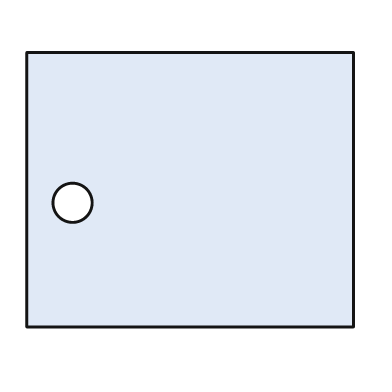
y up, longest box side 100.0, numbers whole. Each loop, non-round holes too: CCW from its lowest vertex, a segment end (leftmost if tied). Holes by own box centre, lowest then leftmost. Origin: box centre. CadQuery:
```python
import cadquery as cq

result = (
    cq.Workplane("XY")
    .moveTo(-50.0, -42.0)
    .lineTo(50.0, -42.0)
    .lineTo(50.0, 42.0)
    .lineTo(-50.0, 42.0)
    .close()
    .moveTo(-36.0, -4.0)
    .circle(6.0)
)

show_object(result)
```